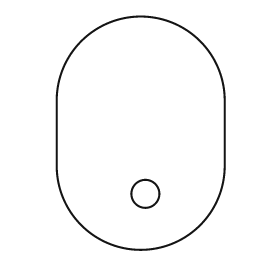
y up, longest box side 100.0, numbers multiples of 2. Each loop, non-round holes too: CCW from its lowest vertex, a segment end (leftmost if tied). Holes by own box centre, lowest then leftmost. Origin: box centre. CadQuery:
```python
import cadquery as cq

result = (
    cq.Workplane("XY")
    .moveTo(-36.0, -14.0)
    .threePointArc((0.0, -50.0), (36.0, -14.0))
    .lineTo(36.0, 14.0)
    .threePointArc((0.0, 50.0), (-36.0, 14.0))
    .close()
    .moveTo(2.0, -26.0)
    .circle(6.0)
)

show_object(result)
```